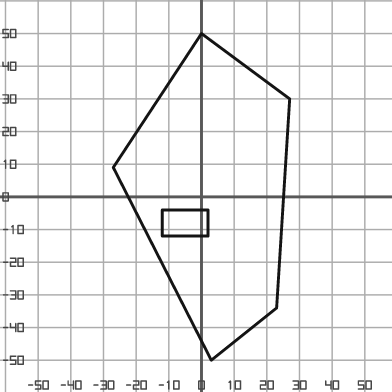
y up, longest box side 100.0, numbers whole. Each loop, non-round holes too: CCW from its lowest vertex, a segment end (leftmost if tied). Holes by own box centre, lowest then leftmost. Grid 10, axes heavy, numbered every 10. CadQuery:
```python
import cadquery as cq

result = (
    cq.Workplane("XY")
    .moveTo(3.0, -50.0)
    .lineTo(23.0, -34.0)
    .lineTo(27.0, 30.0)
    .lineTo(0.0, 50.0)
    .lineTo(-27.0, 9.0)
    .close()
    .moveTo(-12.0, -12.0)
    .lineTo(2.0, -12.0)
    .lineTo(2.0, -4.0)
    .lineTo(-12.0, -4.0)
    .close()
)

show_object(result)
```